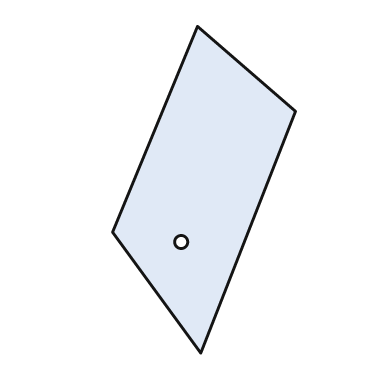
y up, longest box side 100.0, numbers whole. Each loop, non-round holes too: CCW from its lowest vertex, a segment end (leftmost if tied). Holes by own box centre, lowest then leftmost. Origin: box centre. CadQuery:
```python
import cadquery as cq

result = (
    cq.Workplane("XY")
    .moveTo(-1.0, -50.0)
    .lineTo(28.0, 24.0)
    .lineTo(-2.0, 50.0)
    .lineTo(-28.0, -13.0)
    .close()
    .moveTo(-7.0, -16.0)
    .circle(2.0)
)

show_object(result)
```